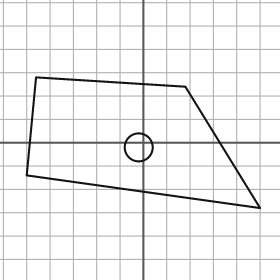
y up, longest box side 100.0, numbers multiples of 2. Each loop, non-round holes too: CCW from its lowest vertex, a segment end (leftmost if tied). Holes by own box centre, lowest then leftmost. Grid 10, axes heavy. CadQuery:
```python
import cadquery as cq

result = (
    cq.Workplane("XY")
    .moveTo(50.0, -28.0)
    .lineTo(18.0, 24.0)
    .lineTo(-46.0, 28.0)
    .lineTo(-50.0, -14.0)
    .close()
    .moveTo(-2.0, -2.0)
    .circle(6.0)
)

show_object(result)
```